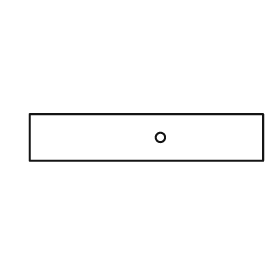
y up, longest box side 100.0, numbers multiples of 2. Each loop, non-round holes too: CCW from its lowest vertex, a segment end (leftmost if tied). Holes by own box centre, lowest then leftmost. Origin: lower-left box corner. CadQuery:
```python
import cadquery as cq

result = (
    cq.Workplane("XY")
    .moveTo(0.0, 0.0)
    .lineTo(100.0, 0.0)
    .lineTo(100.0, 20.0)
    .lineTo(0.0, 20.0)
    .close()
    .moveTo(56.0, 10.0)
    .circle(2.0)
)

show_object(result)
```